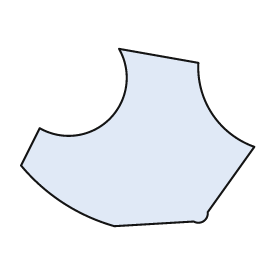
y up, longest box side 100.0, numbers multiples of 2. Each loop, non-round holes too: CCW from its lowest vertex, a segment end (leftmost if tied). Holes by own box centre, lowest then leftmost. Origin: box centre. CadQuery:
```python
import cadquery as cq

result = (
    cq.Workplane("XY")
    .moveTo(-10.0, -38.0)
    .lineTo(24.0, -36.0)
    .threePointArc((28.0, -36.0), (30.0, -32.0))
    .lineTo(50.0, -4.0)
    .threePointArc((32.0, 10.0), (26.0, 32.0))
    .lineTo(-8.0, 38.0)
    .threePointArc((-12.0, 8.0), (-42.0, 4.0))
    .lineTo(-50.0, -12.0)
    .threePointArc((-32.0, -28.0), (-10.0, -38.0))
    .close()
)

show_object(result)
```